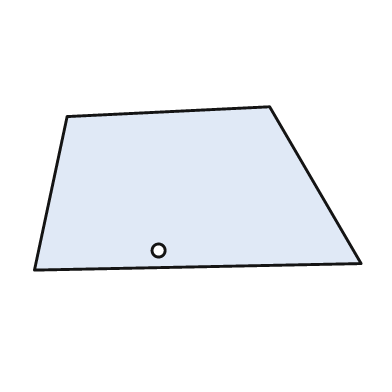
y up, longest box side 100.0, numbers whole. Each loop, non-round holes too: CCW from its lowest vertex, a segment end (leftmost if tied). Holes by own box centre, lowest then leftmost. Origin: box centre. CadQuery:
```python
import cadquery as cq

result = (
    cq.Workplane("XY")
    .moveTo(-50.0, -25.0)
    .lineTo(50.0, -23.0)
    .lineTo(22.0, 25.0)
    .lineTo(-40.0, 22.0)
    .close()
    .moveTo(-12.0, -19.0)
    .circle(2.0)
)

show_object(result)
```